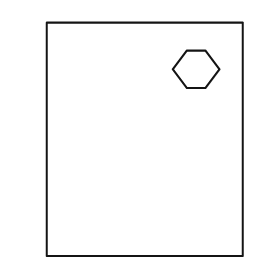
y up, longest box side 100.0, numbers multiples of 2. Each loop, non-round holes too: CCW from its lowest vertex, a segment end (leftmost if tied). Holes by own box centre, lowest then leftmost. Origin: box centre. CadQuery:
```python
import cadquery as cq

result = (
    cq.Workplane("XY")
    .moveTo(-42.0, -50.0)
    .lineTo(42.0, -50.0)
    .lineTo(42.0, 50.0)
    .lineTo(-42.0, 50.0)
    .close()
    .moveTo(18.0, 22.0)
    .lineTo(26.0, 22.0)
    .lineTo(32.0, 30.0)
    .lineTo(26.0, 38.0)
    .lineTo(18.0, 38.0)
    .lineTo(12.0, 30.0)
    .close()
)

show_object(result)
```